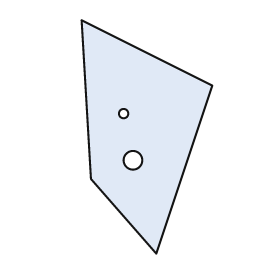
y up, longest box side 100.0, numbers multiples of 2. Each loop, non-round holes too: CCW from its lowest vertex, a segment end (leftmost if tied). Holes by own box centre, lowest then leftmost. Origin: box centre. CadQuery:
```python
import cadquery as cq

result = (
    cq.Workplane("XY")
    .moveTo(4.0, -50.0)
    .lineTo(28.0, 22.0)
    .lineTo(-28.0, 50.0)
    .lineTo(-24.0, -18.0)
    .close()
    .moveTo(-6.0, -10.0)
    .circle(4.0)
    .moveTo(-10.0, 10.0)
    .circle(2.0)
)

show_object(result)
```